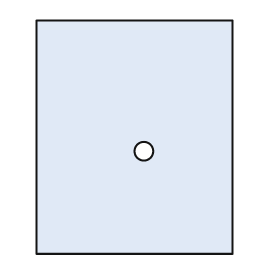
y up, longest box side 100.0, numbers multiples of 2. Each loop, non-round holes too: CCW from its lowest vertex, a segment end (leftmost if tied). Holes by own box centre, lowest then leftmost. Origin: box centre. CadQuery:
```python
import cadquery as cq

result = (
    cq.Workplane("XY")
    .moveTo(-42.0, -50.0)
    .lineTo(42.0, -50.0)
    .lineTo(42.0, 50.0)
    .lineTo(-42.0, 50.0)
    .close()
    .moveTo(4.0, -6.0)
    .circle(4.0)
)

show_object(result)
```